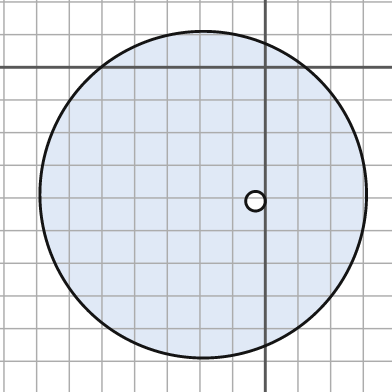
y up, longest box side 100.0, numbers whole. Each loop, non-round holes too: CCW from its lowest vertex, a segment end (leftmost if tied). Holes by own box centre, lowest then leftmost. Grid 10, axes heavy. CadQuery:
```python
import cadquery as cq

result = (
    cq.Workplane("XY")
    .moveTo(-19.0, -39.0)
    .circle(50.0)
    .moveTo(-3.0, -41.0)
    .circle(3.0)
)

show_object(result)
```